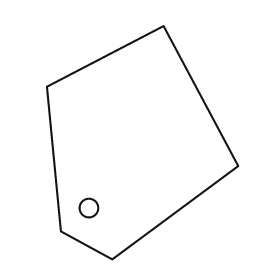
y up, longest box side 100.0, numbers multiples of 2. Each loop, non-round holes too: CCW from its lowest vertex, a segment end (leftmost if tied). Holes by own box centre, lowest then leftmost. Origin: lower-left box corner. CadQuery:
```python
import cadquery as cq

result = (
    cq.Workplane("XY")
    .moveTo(28.0, 0.0)
    .lineTo(82.0, 40.0)
    .lineTo(50.0, 100.0)
    .lineTo(0.0, 74.0)
    .lineTo(6.0, 12.0)
    .close()
    .moveTo(18.0, 22.0)
    .circle(4.0)
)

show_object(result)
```